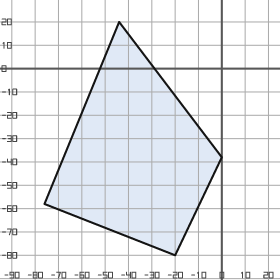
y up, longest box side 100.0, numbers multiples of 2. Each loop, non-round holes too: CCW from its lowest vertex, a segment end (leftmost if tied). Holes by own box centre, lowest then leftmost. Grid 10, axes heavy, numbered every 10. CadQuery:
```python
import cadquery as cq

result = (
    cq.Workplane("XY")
    .moveTo(-20.0, -80.0)
    .lineTo(0.0, -38.0)
    .lineTo(-44.0, 20.0)
    .lineTo(-76.0, -58.0)
    .close()
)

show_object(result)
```